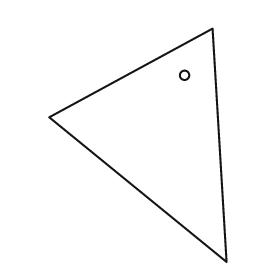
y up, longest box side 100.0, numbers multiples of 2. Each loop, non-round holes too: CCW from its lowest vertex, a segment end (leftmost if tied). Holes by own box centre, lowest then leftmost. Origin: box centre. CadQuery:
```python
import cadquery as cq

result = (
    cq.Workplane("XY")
    .moveTo(38.0, -50.0)
    .lineTo(32.0, 50.0)
    .lineTo(-38.0, 12.0)
    .close()
    .moveTo(20.0, 30.0)
    .circle(2.0)
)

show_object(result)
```